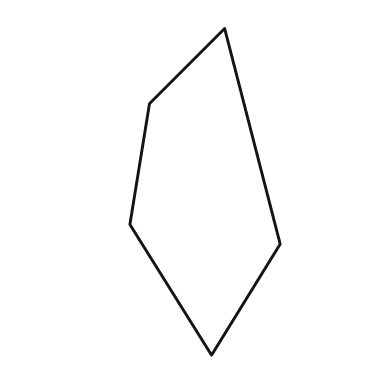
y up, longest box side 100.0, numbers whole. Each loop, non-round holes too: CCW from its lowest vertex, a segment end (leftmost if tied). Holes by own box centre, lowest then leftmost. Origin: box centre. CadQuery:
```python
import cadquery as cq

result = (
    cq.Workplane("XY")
    .moveTo(2.0, -50.0)
    .lineTo(23.0, -16.0)
    .lineTo(6.0, 50.0)
    .lineTo(-17.0, 27.0)
    .lineTo(-23.0, -10.0)
    .close()
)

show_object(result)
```